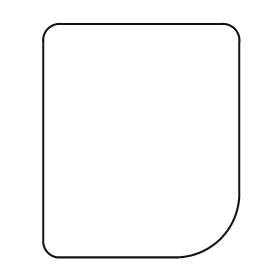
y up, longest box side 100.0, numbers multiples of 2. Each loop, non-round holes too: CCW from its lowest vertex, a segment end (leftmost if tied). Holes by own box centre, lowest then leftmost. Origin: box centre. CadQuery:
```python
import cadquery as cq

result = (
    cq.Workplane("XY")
    .moveTo(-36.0, -50.0)
    .lineTo(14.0, -50.0)
    .threePointArc((34.0, -42.0), (42.0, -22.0))
    .lineTo(42.0, 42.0)
    .threePointArc((40.0, 48.0), (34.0, 50.0))
    .lineTo(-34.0, 50.0)
    .threePointArc((-40.0, 48.0), (-42.0, 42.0))
    .lineTo(-42.0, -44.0)
    .threePointArc((-40.0, -48.0), (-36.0, -50.0))
    .close()
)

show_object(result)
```